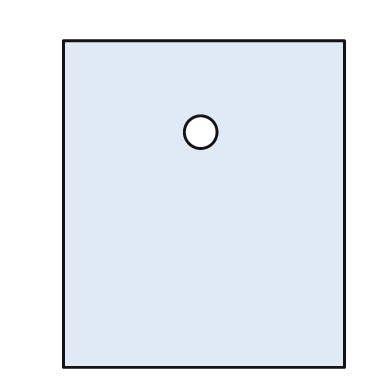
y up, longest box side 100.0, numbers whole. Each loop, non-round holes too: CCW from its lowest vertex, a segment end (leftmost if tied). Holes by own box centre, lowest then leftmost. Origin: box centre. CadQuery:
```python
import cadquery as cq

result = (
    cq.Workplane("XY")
    .moveTo(-43.0, -50.0)
    .lineTo(43.0, -50.0)
    .lineTo(43.0, 50.0)
    .lineTo(-43.0, 50.0)
    .close()
    .moveTo(-1.0, 22.0)
    .circle(5.0)
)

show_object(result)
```